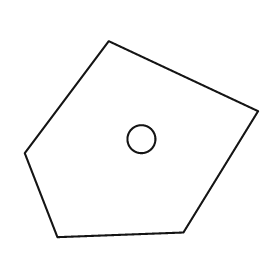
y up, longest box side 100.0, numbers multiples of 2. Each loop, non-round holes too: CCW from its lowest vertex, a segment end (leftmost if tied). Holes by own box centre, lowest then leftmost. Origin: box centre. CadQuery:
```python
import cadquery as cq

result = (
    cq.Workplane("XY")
    .moveTo(-36.0, -42.0)
    .lineTo(18.0, -40.0)
    .lineTo(50.0, 12.0)
    .lineTo(-14.0, 42.0)
    .lineTo(-50.0, -6.0)
    .close()
    .moveTo(0.0, 0.0)
    .circle(6.0)
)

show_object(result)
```